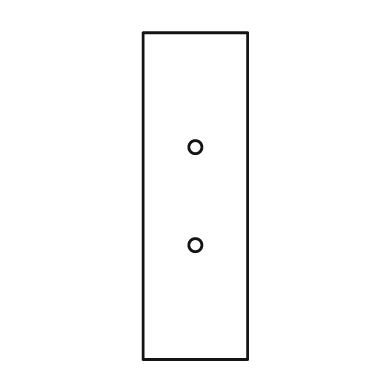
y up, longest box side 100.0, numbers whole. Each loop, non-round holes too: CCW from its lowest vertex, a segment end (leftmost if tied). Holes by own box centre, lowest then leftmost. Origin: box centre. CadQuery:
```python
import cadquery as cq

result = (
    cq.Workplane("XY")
    .moveTo(-16.0, -50.0)
    .lineTo(16.0, -50.0)
    .lineTo(16.0, 50.0)
    .lineTo(-16.0, 50.0)
    .close()
    .moveTo(0.0, -15.0)
    .circle(2.0)
    .moveTo(0.0, 15.0)
    .circle(2.0)
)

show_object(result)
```